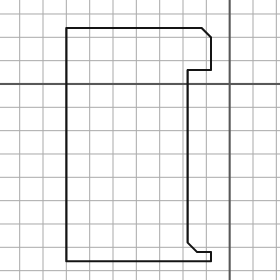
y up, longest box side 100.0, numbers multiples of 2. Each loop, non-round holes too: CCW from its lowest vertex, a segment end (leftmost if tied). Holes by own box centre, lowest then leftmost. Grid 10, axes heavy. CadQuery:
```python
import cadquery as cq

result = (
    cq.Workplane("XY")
    .moveTo(-70.0, -76.0)
    .lineTo(-8.0, -76.0)
    .lineTo(-8.0, -72.0)
    .lineTo(-14.0, -72.0)
    .lineTo(-18.0, -68.0)
    .lineTo(-18.0, 6.0)
    .lineTo(-8.0, 6.0)
    .lineTo(-8.0, 20.0)
    .lineTo(-12.0, 24.0)
    .lineTo(-70.0, 24.0)
    .close()
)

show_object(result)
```